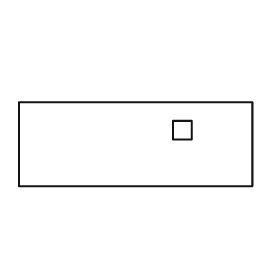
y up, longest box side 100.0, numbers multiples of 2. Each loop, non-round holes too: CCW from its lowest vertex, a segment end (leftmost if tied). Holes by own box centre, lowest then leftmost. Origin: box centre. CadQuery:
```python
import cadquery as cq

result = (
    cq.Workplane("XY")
    .moveTo(-50.0, -18.0)
    .lineTo(50.0, -18.0)
    .lineTo(50.0, 18.0)
    .lineTo(-50.0, 18.0)
    .close()
    .moveTo(16.0, 2.0)
    .lineTo(24.0, 2.0)
    .lineTo(24.0, 10.0)
    .lineTo(16.0, 10.0)
    .close()
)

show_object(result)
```